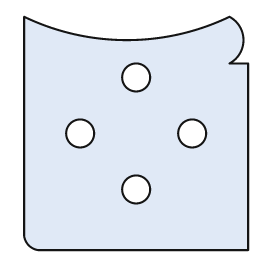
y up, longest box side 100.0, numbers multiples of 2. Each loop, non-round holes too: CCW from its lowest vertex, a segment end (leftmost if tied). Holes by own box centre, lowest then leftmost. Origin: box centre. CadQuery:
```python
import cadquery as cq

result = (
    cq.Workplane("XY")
    .moveTo(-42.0, -50.0)
    .lineTo(48.0, -50.0)
    .lineTo(48.0, 30.0)
    .lineTo(40.0, 30.0)
    .threePointArc((46.0, 40.0), (40.0, 50.0))
    .threePointArc((-4.0, 40.0), (-48.0, 50.0))
    .lineTo(-48.0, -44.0)
    .threePointArc((-46.0, -48.0), (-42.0, -50.0))
    .close()
    .moveTo(0.0, -24.0)
    .circle(6.0)
    .moveTo(-24.0, 0.0)
    .circle(6.0)
    .moveTo(24.0, 0.0)
    .circle(6.0)
    .moveTo(0.0, 24.0)
    .circle(6.0)
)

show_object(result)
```